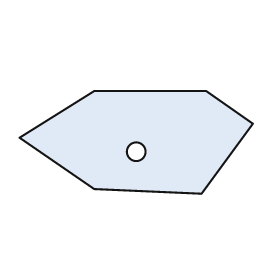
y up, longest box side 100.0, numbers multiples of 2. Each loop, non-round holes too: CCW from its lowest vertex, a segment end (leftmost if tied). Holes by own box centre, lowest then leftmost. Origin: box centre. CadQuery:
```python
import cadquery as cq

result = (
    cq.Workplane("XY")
    .moveTo(28.0, -22.0)
    .lineTo(50.0, 8.0)
    .lineTo(30.0, 22.0)
    .lineTo(-18.0, 22.0)
    .lineTo(-50.0, 2.0)
    .lineTo(-18.0, -20.0)
    .close()
    .moveTo(0.0, -4.0)
    .circle(4.0)
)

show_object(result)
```